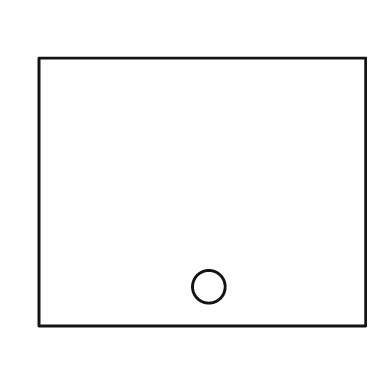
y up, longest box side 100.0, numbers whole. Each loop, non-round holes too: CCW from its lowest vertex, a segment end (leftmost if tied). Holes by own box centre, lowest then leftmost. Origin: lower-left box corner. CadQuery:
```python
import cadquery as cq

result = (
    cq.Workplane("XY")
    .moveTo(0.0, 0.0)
    .lineTo(100.0, 0.0)
    .lineTo(100.0, 82.0)
    .lineTo(0.0, 82.0)
    .close()
    .moveTo(52.0, 12.0)
    .circle(5.0)
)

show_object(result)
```